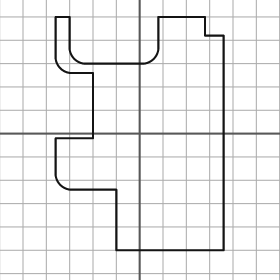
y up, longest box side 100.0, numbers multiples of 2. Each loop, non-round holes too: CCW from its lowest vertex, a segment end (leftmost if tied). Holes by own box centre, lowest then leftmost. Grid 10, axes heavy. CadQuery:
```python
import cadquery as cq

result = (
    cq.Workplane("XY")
    .moveTo(-10.0, -50.0)
    .lineTo(36.0, -50.0)
    .lineTo(36.0, 42.0)
    .lineTo(28.0, 42.0)
    .lineTo(28.0, 50.0)
    .lineTo(8.0, 50.0)
    .lineTo(8.0, 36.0)
    .threePointArc((6.0, 32.0), (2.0, 30.0))
    .lineTo(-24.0, 30.0)
    .threePointArc((-28.0, 32.0), (-30.0, 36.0))
    .lineTo(-30.0, 50.0)
    .lineTo(-36.0, 50.0)
    .lineTo(-36.0, 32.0)
    .threePointArc((-34.0, 28.0), (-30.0, 26.0))
    .lineTo(-20.0, 26.0)
    .lineTo(-20.0, -2.0)
    .lineTo(-36.0, -2.0)
    .lineTo(-36.0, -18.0)
    .threePointArc((-34.0, -22.0), (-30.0, -24.0))
    .lineTo(-10.0, -24.0)
    .close()
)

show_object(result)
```